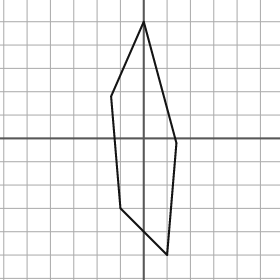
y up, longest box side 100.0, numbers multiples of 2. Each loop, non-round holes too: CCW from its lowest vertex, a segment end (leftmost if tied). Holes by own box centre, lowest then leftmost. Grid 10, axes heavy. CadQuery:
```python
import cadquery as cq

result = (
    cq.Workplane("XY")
    .moveTo(10.0, -50.0)
    .lineTo(14.0, -2.0)
    .lineTo(0.0, 50.0)
    .lineTo(-14.0, 18.0)
    .lineTo(-10.0, -30.0)
    .close()
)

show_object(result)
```